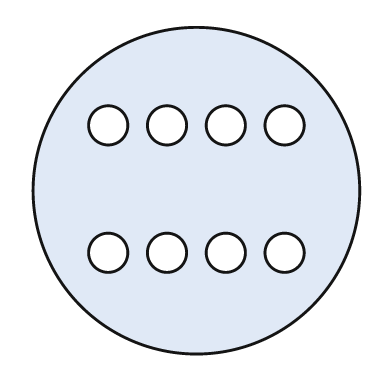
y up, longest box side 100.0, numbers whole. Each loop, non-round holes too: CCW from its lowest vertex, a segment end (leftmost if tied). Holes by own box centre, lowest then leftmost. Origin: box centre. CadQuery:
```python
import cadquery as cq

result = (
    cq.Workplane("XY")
    .moveTo(0.0, 0.0)
    .circle(50.0)
    .moveTo(-27.0, -19.0)
    .circle(6.0)
    .moveTo(-9.0, -19.0)
    .circle(6.0)
    .moveTo(9.0, -19.0)
    .circle(6.0)
    .moveTo(27.0, -19.0)
    .circle(6.0)
    .moveTo(-27.0, 20.0)
    .circle(6.0)
    .moveTo(-9.0, 20.0)
    .circle(6.0)
    .moveTo(9.0, 20.0)
    .circle(6.0)
    .moveTo(27.0, 20.0)
    .circle(6.0)
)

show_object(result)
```